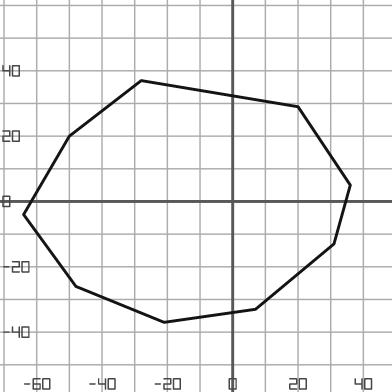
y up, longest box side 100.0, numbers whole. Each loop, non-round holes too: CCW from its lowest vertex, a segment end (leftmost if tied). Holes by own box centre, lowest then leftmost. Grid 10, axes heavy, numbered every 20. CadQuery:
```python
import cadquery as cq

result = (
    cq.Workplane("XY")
    .moveTo(-21.0, -37.0)
    .lineTo(7.0, -33.0)
    .lineTo(31.0, -13.0)
    .lineTo(36.0, 5.0)
    .lineTo(20.0, 29.0)
    .lineTo(-28.0, 37.0)
    .lineTo(-50.0, 20.0)
    .lineTo(-64.0, -4.0)
    .lineTo(-48.0, -26.0)
    .close()
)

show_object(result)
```